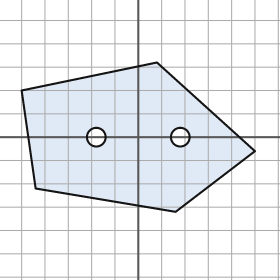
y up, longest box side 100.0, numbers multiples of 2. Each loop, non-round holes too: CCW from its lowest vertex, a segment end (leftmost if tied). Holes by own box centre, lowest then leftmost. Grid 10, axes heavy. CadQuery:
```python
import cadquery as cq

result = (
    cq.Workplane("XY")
    .moveTo(16.0, -32.0)
    .lineTo(50.0, -6.0)
    .lineTo(8.0, 32.0)
    .lineTo(-50.0, 20.0)
    .lineTo(-44.0, -22.0)
    .close()
    .moveTo(-18.0, 0.0)
    .circle(4.0)
    .moveTo(18.0, 0.0)
    .circle(4.0)
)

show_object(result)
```